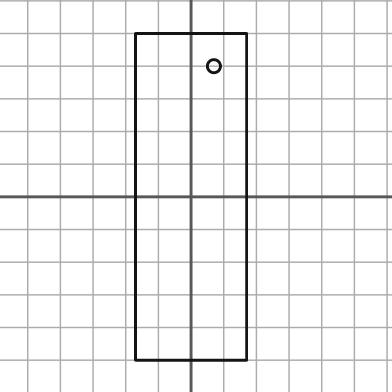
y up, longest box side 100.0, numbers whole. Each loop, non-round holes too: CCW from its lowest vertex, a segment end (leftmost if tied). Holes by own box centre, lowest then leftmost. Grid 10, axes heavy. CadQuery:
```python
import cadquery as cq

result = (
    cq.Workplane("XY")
    .moveTo(-17.0, -50.0)
    .lineTo(17.0, -50.0)
    .lineTo(17.0, 50.0)
    .lineTo(-17.0, 50.0)
    .close()
    .moveTo(7.0, 40.0)
    .circle(2.0)
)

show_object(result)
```